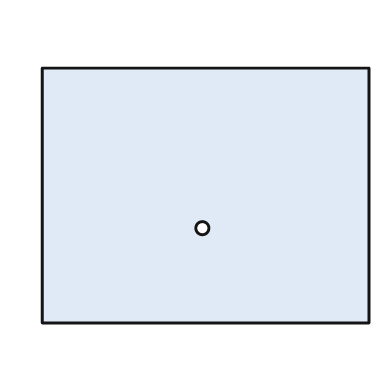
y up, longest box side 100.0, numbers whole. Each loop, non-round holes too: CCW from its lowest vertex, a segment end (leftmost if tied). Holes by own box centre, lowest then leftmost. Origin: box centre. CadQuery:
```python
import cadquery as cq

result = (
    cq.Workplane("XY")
    .moveTo(-50.0, -39.0)
    .lineTo(50.0, -39.0)
    .lineTo(50.0, 39.0)
    .lineTo(-50.0, 39.0)
    .close()
    .moveTo(-1.0, -10.0)
    .circle(2.0)
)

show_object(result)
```